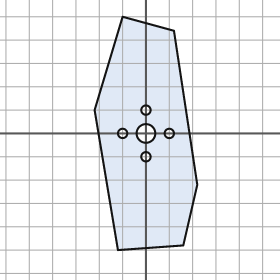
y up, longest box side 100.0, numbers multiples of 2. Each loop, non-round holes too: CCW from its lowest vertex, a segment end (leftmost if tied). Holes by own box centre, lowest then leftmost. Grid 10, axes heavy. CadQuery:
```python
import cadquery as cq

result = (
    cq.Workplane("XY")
    .moveTo(-12.0, -50.0)
    .lineTo(16.0, -48.0)
    .lineTo(22.0, -22.0)
    .lineTo(12.0, 44.0)
    .lineTo(-10.0, 50.0)
    .lineTo(-22.0, 10.0)
    .close()
    .moveTo(0.0, -10.0)
    .circle(2.0)
    .moveTo(-10.0, 0.0)
    .circle(2.0)
    .moveTo(0.0, 0.0)
    .circle(4.0)
    .moveTo(10.0, 0.0)
    .circle(2.0)
    .moveTo(0.0, 10.0)
    .circle(2.0)
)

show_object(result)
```